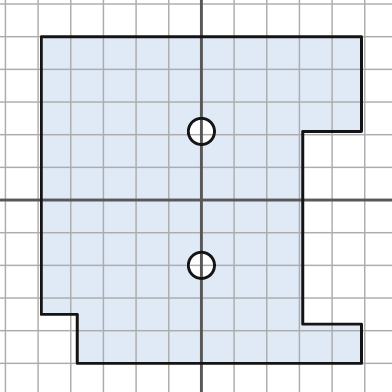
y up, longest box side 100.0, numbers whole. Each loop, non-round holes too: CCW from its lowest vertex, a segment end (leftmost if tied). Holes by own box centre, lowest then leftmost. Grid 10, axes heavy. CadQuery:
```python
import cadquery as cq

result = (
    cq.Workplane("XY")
    .moveTo(-38.0, -50.0)
    .lineTo(49.0, -50.0)
    .lineTo(49.0, -38.0)
    .lineTo(31.0, -38.0)
    .lineTo(31.0, 21.0)
    .lineTo(49.0, 21.0)
    .lineTo(49.0, 50.0)
    .lineTo(-49.0, 50.0)
    .lineTo(-49.0, -35.0)
    .lineTo(-38.0, -35.0)
    .close()
    .moveTo(0.0, -20.0)
    .circle(4.0)
    .moveTo(0.0, 21.0)
    .circle(4.0)
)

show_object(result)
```